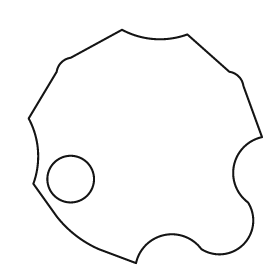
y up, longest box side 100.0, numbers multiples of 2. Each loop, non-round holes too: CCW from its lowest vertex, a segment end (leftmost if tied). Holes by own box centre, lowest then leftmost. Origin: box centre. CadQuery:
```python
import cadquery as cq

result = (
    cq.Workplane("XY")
    .moveTo(-4.0, -50.0)
    .threePointArc((8.0, -38.0), (24.0, -44.0))
    .threePointArc((42.0, -42.0), (44.0, -24.0))
    .threePointArc((38.0, -8.0), (50.0, 4.0))
    .lineTo(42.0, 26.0)
    .threePointArc((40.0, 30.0), (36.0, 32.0))
    .lineTo(18.0, 48.0)
    .threePointArc((4.0, 46.0), (-10.0, 50.0))
    .lineTo(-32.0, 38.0)
    .threePointArc((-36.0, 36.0), (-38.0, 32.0))
    .lineTo(-50.0, 12.0)
    .threePointArc((-46.0, -2.0), (-48.0, -16.0))
    .lineTo(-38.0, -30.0)
    .threePointArc((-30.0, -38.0), (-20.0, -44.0))
    .close()
    .moveTo(-32.0, -14.0)
    .circle(10.0)
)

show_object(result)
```